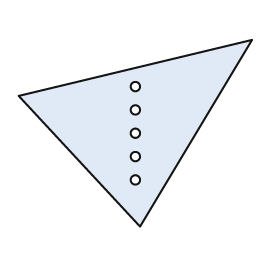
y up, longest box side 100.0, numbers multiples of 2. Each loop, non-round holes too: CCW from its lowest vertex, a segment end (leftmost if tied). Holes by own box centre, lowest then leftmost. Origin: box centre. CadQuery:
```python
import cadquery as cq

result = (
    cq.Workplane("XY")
    .moveTo(2.0, -40.0)
    .lineTo(50.0, 40.0)
    .lineTo(-50.0, 16.0)
    .close()
    .moveTo(0.0, -20.0)
    .circle(2.0)
    .moveTo(0.0, -10.0)
    .circle(2.0)
    .moveTo(0.0, 0.0)
    .circle(2.0)
    .moveTo(0.0, 10.0)
    .circle(2.0)
    .moveTo(0.0, 20.0)
    .circle(2.0)
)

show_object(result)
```